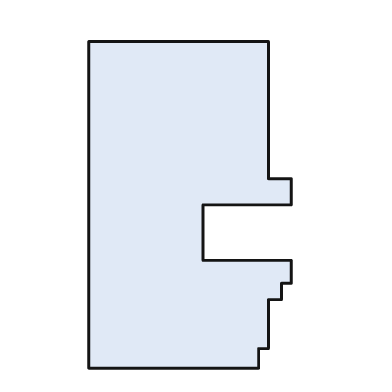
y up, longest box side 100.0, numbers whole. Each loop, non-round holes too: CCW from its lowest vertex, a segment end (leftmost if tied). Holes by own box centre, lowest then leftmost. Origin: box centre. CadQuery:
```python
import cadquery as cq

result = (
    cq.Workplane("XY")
    .moveTo(-31.0, -50.0)
    .lineTo(21.0, -50.0)
    .lineTo(21.0, -44.0)
    .lineTo(24.0, -44.0)
    .lineTo(24.0, -29.0)
    .lineTo(28.0, -29.0)
    .lineTo(28.0, -24.0)
    .lineTo(31.0, -24.0)
    .lineTo(31.0, -17.0)
    .lineTo(4.0, -17.0)
    .lineTo(4.0, 0.0)
    .lineTo(31.0, 0.0)
    .lineTo(31.0, 8.0)
    .lineTo(24.0, 8.0)
    .lineTo(24.0, 50.0)
    .lineTo(-31.0, 50.0)
    .close()
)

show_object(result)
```